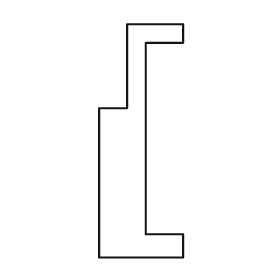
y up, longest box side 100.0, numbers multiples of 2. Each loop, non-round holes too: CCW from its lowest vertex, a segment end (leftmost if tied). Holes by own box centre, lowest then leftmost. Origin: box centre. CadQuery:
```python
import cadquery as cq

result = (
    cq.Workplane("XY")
    .moveTo(-18.0, -50.0)
    .lineTo(18.0, -50.0)
    .lineTo(18.0, -40.0)
    .lineTo(2.0, -40.0)
    .lineTo(2.0, 42.0)
    .lineTo(18.0, 42.0)
    .lineTo(18.0, 50.0)
    .lineTo(-6.0, 50.0)
    .lineTo(-6.0, 14.0)
    .lineTo(-18.0, 14.0)
    .close()
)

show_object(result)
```